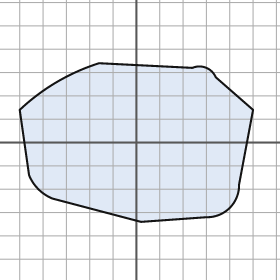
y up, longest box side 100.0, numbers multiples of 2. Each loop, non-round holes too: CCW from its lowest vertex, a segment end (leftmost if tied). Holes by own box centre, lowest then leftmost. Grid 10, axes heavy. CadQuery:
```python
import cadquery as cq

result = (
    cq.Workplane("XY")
    .moveTo(2.0, -34.0)
    .lineTo(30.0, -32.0)
    .threePointArc((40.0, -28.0), (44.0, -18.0))
    .lineTo(50.0, 14.0)
    .lineTo(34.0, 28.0)
    .threePointArc((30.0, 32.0), (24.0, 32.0))
    .lineTo(-16.0, 34.0)
    .threePointArc((-34.0, 26.0), (-50.0, 14.0))
    .lineTo(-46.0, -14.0)
    .threePointArc((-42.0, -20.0), (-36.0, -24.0))
    .close()
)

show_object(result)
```